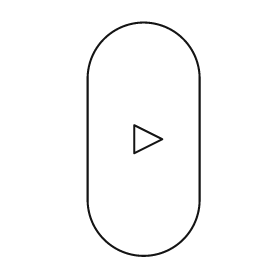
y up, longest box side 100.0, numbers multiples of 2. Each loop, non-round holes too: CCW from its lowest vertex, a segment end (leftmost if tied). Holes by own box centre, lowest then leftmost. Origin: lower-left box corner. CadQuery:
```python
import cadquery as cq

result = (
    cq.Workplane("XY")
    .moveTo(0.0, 24.0)
    .threePointArc((24.0, 0.0), (48.0, 24.0))
    .lineTo(48.0, 76.0)
    .threePointArc((24.0, 100.0), (0.0, 76.0))
    .close()
    .moveTo(20.0, 44.0)
    .lineTo(32.0, 50.0)
    .lineTo(20.0, 56.0)
    .close()
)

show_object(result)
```